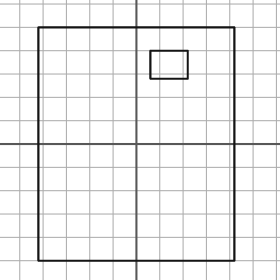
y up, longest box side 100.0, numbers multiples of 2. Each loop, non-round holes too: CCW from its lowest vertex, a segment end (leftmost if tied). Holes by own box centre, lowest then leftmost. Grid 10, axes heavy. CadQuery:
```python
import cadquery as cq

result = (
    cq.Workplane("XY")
    .moveTo(-42.0, -50.0)
    .lineTo(42.0, -50.0)
    .lineTo(42.0, 50.0)
    .lineTo(-42.0, 50.0)
    .close()
    .moveTo(6.0, 28.0)
    .lineTo(22.0, 28.0)
    .lineTo(22.0, 40.0)
    .lineTo(6.0, 40.0)
    .close()
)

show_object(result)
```